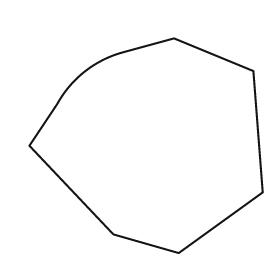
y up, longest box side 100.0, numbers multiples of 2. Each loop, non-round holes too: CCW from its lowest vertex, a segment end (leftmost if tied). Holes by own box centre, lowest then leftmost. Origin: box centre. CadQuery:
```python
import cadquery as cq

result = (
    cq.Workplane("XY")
    .moveTo(14.0, -46.0)
    .lineTo(50.0, -20.0)
    .lineTo(46.0, 32.0)
    .lineTo(12.0, 46.0)
    .lineTo(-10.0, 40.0)
    .threePointArc((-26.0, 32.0), (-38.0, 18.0))
    .lineTo(-50.0, 0.0)
    .lineTo(-14.0, -38.0)
    .close()
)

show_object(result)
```